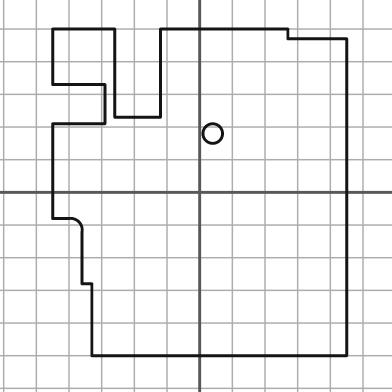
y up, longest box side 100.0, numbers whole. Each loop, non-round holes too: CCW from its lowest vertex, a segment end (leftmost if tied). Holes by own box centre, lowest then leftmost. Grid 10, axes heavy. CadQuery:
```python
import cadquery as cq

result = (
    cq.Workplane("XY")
    .moveTo(-33.0, -50.0)
    .lineTo(45.0, -50.0)
    .lineTo(45.0, 47.0)
    .lineTo(27.0, 47.0)
    .lineTo(27.0, 50.0)
    .lineTo(-12.0, 50.0)
    .lineTo(-12.0, 23.0)
    .lineTo(-26.0, 23.0)
    .lineTo(-26.0, 50.0)
    .lineTo(-45.0, 50.0)
    .lineTo(-45.0, 33.0)
    .lineTo(-29.0, 33.0)
    .lineTo(-29.0, 21.0)
    .lineTo(-45.0, 21.0)
    .lineTo(-45.0, -8.0)
    .lineTo(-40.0, -8.0)
    .threePointArc((-37.0, -9.0), (-36.0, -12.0))
    .lineTo(-36.0, -28.0)
    .lineTo(-33.0, -28.0)
    .close()
    .moveTo(4.0, 18.0)
    .circle(3.0)
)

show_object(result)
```